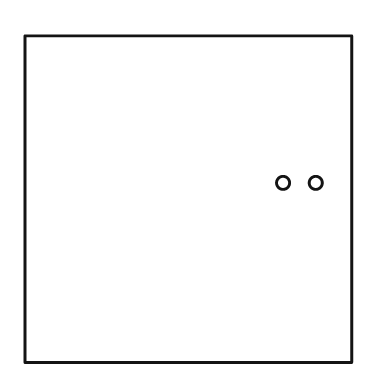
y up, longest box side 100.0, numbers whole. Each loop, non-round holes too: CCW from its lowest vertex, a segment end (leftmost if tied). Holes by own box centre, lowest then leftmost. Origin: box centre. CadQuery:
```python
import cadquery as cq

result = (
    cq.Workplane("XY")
    .moveTo(-50.0, -50.0)
    .lineTo(50.0, -50.0)
    .lineTo(50.0, 50.0)
    .lineTo(-50.0, 50.0)
    .close()
    .moveTo(29.0, 5.0)
    .circle(2.0)
    .moveTo(39.0, 5.0)
    .circle(2.0)
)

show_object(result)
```